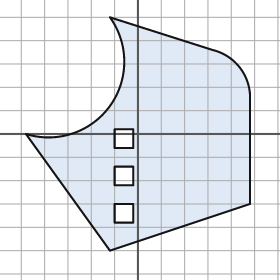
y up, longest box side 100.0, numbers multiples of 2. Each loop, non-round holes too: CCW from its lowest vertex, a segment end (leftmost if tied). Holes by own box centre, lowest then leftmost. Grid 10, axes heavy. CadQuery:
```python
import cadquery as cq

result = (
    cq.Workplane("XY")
    .moveTo(-12.0, -50.0)
    .lineTo(48.0, -30.0)
    .lineTo(48.0, 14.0)
    .threePointArc((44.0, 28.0), (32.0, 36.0))
    .lineTo(-12.0, 50.0)
    .threePointArc((-12.0, 12.0), (-48.0, 0.0))
    .close()
    .moveTo(-10.0, -38.0)
    .lineTo(-2.0, -38.0)
    .lineTo(-2.0, -30.0)
    .lineTo(-10.0, -30.0)
    .close()
    .moveTo(-10.0, -22.0)
    .lineTo(-2.0, -22.0)
    .lineTo(-2.0, -14.0)
    .lineTo(-10.0, -14.0)
    .close()
    .moveTo(-10.0, -6.0)
    .lineTo(-2.0, -6.0)
    .lineTo(-2.0, 2.0)
    .lineTo(-10.0, 2.0)
    .close()
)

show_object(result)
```